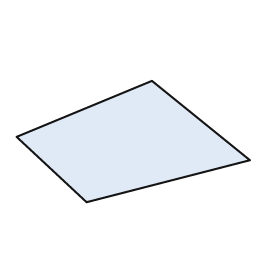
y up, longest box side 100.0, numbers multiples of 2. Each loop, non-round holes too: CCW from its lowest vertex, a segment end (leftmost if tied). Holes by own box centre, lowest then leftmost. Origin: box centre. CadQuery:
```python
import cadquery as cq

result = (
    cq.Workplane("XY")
    .moveTo(-20.0, -26.0)
    .lineTo(50.0, -8.0)
    .lineTo(8.0, 26.0)
    .lineTo(-50.0, 2.0)
    .close()
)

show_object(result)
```